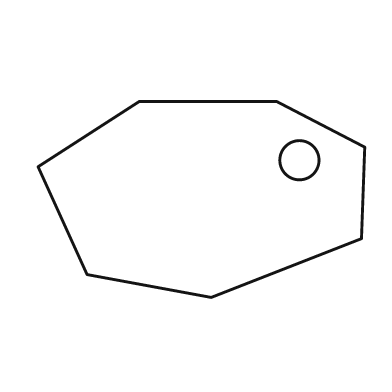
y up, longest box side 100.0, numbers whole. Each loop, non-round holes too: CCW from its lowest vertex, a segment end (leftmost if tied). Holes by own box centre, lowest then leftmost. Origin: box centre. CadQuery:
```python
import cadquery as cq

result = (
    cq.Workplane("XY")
    .moveTo(3.0, -30.0)
    .lineTo(49.0, -12.0)
    .lineTo(50.0, 16.0)
    .lineTo(23.0, 30.0)
    .lineTo(-19.0, 30.0)
    .lineTo(-50.0, 10.0)
    .lineTo(-35.0, -23.0)
    .close()
    .moveTo(30.0, 12.0)
    .circle(6.0)
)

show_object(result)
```